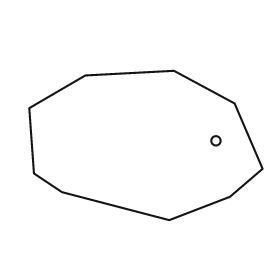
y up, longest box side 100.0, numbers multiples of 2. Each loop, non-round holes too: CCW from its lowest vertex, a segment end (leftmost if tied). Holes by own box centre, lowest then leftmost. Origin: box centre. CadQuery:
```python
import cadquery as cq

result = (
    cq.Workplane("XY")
    .moveTo(10.0, -32.0)
    .lineTo(36.0, -22.0)
    .lineTo(50.0, -10.0)
    .lineTo(38.0, 18.0)
    .lineTo(12.0, 32.0)
    .lineTo(-26.0, 30.0)
    .lineTo(-50.0, 16.0)
    .lineTo(-48.0, -12.0)
    .lineTo(-36.0, -20.0)
    .close()
    .moveTo(30.0, 2.0)
    .circle(2.0)
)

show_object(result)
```